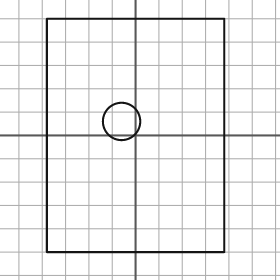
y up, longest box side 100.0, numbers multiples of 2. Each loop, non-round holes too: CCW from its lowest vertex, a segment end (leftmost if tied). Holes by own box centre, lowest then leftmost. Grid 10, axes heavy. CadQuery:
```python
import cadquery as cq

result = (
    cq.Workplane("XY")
    .moveTo(-38.0, -50.0)
    .lineTo(38.0, -50.0)
    .lineTo(38.0, 50.0)
    .lineTo(-38.0, 50.0)
    .close()
    .moveTo(-6.0, 6.0)
    .circle(8.0)
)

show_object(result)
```